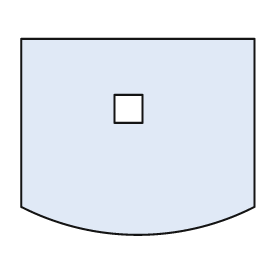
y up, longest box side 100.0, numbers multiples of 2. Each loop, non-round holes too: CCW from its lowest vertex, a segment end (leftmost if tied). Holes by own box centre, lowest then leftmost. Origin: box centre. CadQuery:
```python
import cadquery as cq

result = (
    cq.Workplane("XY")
    .moveTo(-50.0, -30.0)
    .threePointArc((0.0, -42.0), (50.0, -30.0))
    .lineTo(50.0, 42.0)
    .lineTo(-50.0, 42.0)
    .close()
    .moveTo(-10.0, 6.0)
    .lineTo(2.0, 6.0)
    .lineTo(2.0, 18.0)
    .lineTo(-10.0, 18.0)
    .close()
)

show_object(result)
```